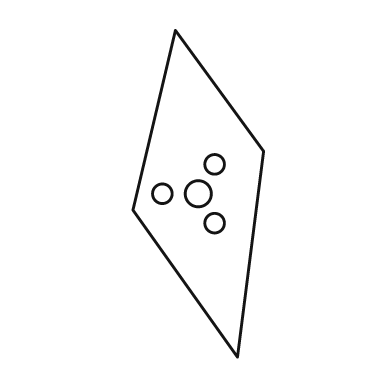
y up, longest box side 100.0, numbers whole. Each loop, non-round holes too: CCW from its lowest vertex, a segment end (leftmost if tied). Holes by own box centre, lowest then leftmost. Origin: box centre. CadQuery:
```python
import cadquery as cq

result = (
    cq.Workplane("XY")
    .moveTo(12.0, -50.0)
    .lineTo(20.0, 13.0)
    .lineTo(-7.0, 50.0)
    .lineTo(-20.0, -5.0)
    .close()
    .moveTo(5.0, -9.0)
    .circle(3.0)
    .moveTo(-11.0, 0.0)
    .circle(3.0)
    .moveTo(0.0, 0.0)
    .circle(4.0)
    .moveTo(5.0, 9.0)
    .circle(3.0)
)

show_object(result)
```